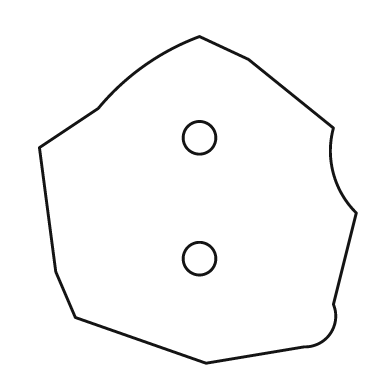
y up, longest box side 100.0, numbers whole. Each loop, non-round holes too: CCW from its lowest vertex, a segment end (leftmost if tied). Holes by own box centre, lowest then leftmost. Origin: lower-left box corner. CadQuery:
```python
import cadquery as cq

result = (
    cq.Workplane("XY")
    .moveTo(51.0, 0.0)
    .lineTo(81.0, 5.0)
    .threePointArc((89.0, 9.0), (90.0, 18.0))
    .lineTo(97.0, 46.0)
    .threePointArc((90.0, 58.0), (90.0, 72.0))
    .lineTo(64.0, 93.0)
    .lineTo(49.0, 100.0)
    .threePointArc((32.0, 91.0), (18.0, 78.0))
    .lineTo(0.0, 66.0)
    .lineTo(5.0, 28.0)
    .lineTo(11.0, 14.0)
    .close()
    .moveTo(49.0, 32.0)
    .circle(5.0)
    .moveTo(49.0, 69.0)
    .circle(5.0)
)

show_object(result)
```